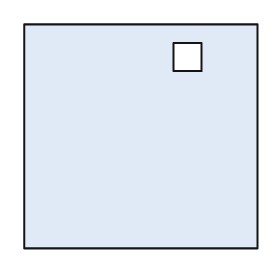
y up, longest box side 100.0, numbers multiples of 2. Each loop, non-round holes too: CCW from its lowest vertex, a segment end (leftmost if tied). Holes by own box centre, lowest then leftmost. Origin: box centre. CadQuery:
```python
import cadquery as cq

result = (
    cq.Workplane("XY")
    .moveTo(-50.0, -48.0)
    .lineTo(50.0, -48.0)
    .lineTo(50.0, 48.0)
    .lineTo(-50.0, 48.0)
    .close()
    .moveTo(14.0, 28.0)
    .lineTo(26.0, 28.0)
    .lineTo(26.0, 40.0)
    .lineTo(14.0, 40.0)
    .close()
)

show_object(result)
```